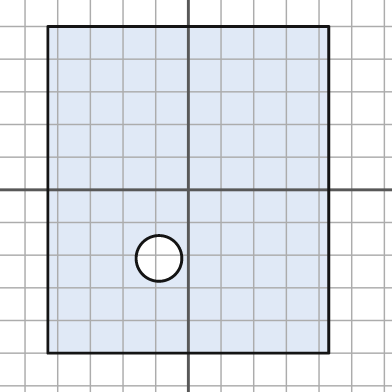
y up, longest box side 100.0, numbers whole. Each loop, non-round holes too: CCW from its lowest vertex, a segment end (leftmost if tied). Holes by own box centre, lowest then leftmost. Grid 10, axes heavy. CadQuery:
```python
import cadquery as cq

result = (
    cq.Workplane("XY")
    .moveTo(-43.0, -50.0)
    .lineTo(43.0, -50.0)
    .lineTo(43.0, 50.0)
    .lineTo(-43.0, 50.0)
    .close()
    .moveTo(-9.0, -21.0)
    .circle(7.0)
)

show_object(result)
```